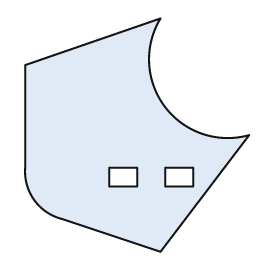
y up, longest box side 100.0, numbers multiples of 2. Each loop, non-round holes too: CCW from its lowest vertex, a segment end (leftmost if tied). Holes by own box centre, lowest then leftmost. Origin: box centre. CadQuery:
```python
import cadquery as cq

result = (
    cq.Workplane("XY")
    .moveTo(10.0, -50.0)
    .lineTo(48.0, 0.0)
    .threePointArc((12.0, 12.0), (10.0, 50.0))
    .lineTo(-48.0, 30.0)
    .lineTo(-48.0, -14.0)
    .threePointArc((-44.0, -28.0), (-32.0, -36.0))
    .close()
    .moveTo(-12.0, -22.0)
    .lineTo(0.0, -22.0)
    .lineTo(0.0, -14.0)
    .lineTo(-12.0, -14.0)
    .close()
    .moveTo(12.0, -22.0)
    .lineTo(24.0, -22.0)
    .lineTo(24.0, -14.0)
    .lineTo(12.0, -14.0)
    .close()
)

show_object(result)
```